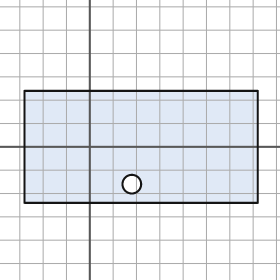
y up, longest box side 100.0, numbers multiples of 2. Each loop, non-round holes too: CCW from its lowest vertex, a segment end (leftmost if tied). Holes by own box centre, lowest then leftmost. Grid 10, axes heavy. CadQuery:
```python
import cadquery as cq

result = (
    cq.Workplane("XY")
    .moveTo(-28.0, -24.0)
    .lineTo(72.0, -24.0)
    .lineTo(72.0, 24.0)
    .lineTo(-28.0, 24.0)
    .close()
    .moveTo(18.0, -16.0)
    .circle(4.0)
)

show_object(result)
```